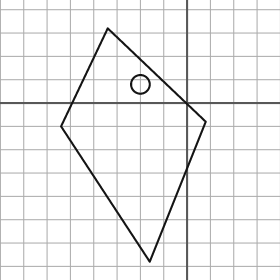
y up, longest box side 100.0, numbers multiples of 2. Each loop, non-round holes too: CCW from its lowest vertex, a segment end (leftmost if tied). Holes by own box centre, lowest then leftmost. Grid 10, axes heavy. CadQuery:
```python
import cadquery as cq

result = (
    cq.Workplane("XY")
    .moveTo(-16.0, -68.0)
    .lineTo(8.0, -8.0)
    .lineTo(-34.0, 32.0)
    .lineTo(-54.0, -10.0)
    .close()
    .moveTo(-20.0, 8.0)
    .circle(4.0)
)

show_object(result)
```